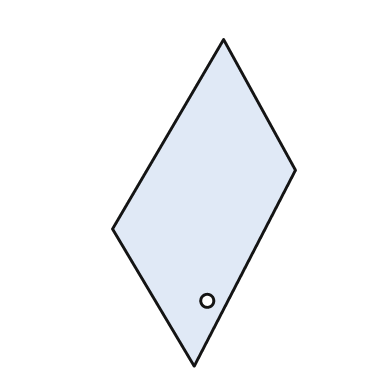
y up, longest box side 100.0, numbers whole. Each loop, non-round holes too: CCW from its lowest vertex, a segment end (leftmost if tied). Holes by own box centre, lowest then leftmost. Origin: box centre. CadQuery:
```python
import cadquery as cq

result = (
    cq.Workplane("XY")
    .moveTo(-3.0, -50.0)
    .lineTo(28.0, 10.0)
    .lineTo(6.0, 50.0)
    .lineTo(-28.0, -8.0)
    .close()
    .moveTo(1.0, -30.0)
    .circle(2.0)
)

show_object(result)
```